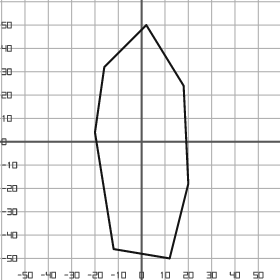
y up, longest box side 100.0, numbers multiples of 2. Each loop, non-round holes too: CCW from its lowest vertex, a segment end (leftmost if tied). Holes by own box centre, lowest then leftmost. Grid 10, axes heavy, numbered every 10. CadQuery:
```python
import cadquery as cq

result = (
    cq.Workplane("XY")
    .moveTo(12.0, -50.0)
    .lineTo(20.0, -18.0)
    .lineTo(18.0, 24.0)
    .lineTo(2.0, 50.0)
    .lineTo(-16.0, 32.0)
    .lineTo(-20.0, 4.0)
    .lineTo(-12.0, -46.0)
    .close()
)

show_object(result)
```